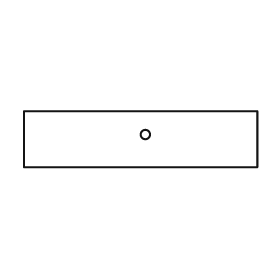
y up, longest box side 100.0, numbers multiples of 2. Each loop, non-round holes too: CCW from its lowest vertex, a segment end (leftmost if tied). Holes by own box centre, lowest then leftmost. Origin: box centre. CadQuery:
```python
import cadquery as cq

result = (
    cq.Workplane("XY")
    .moveTo(-50.0, -12.0)
    .lineTo(50.0, -12.0)
    .lineTo(50.0, 12.0)
    .lineTo(-50.0, 12.0)
    .close()
    .moveTo(2.0, 2.0)
    .circle(2.0)
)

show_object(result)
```